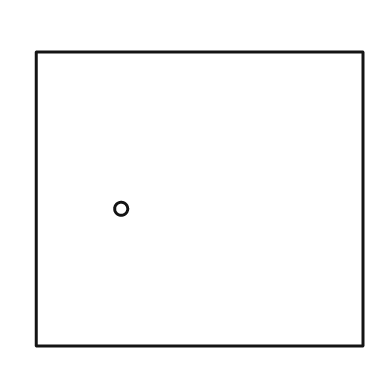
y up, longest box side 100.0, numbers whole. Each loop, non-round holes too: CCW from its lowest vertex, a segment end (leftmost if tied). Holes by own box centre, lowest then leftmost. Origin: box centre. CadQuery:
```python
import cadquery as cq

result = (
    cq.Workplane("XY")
    .moveTo(-50.0, -45.0)
    .lineTo(50.0, -45.0)
    .lineTo(50.0, 45.0)
    .lineTo(-50.0, 45.0)
    .close()
    .moveTo(-24.0, -3.0)
    .circle(2.0)
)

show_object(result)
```